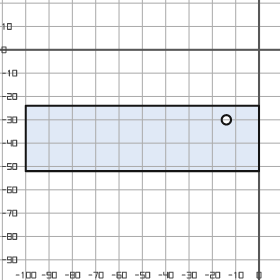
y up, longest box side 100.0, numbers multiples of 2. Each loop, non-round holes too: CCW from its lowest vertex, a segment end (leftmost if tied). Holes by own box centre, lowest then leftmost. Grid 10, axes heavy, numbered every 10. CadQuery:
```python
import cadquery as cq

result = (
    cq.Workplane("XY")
    .moveTo(-100.0, -52.0)
    .lineTo(0.0, -52.0)
    .lineTo(0.0, -24.0)
    .lineTo(-100.0, -24.0)
    .close()
    .moveTo(-14.0, -30.0)
    .circle(2.0)
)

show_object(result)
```